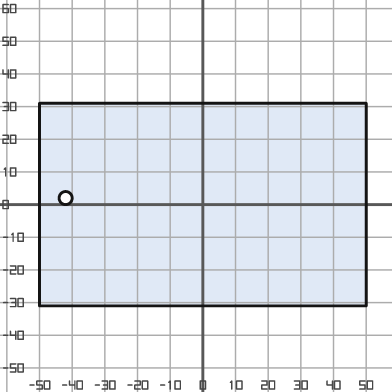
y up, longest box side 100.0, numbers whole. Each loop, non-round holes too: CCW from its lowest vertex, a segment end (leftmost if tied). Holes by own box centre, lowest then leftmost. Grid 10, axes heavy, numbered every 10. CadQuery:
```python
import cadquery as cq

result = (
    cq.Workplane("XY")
    .moveTo(-50.0, -31.0)
    .lineTo(50.0, -31.0)
    .lineTo(50.0, 31.0)
    .lineTo(-50.0, 31.0)
    .close()
    .moveTo(-42.0, 2.0)
    .circle(2.0)
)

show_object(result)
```